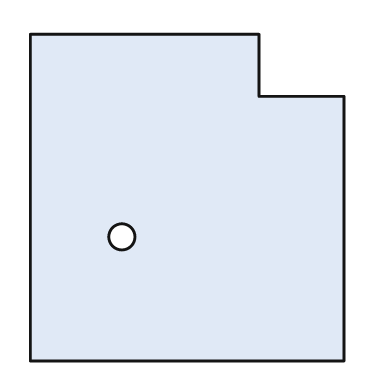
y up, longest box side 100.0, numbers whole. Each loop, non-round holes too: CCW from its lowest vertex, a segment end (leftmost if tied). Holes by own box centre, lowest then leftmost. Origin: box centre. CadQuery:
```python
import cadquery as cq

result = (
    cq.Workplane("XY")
    .moveTo(-48.0, -50.0)
    .lineTo(48.0, -50.0)
    .lineTo(48.0, 31.0)
    .lineTo(22.0, 31.0)
    .lineTo(22.0, 50.0)
    .lineTo(-48.0, 50.0)
    .close()
    .moveTo(-20.0, -12.0)
    .circle(4.0)
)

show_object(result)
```